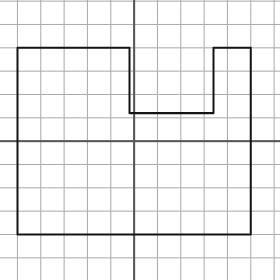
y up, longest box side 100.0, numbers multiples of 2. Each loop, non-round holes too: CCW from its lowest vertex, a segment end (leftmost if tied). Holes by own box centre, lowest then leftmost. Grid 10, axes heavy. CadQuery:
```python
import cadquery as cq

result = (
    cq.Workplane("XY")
    .moveTo(-50.0, -40.0)
    .lineTo(50.0, -40.0)
    .lineTo(50.0, 40.0)
    .lineTo(34.0, 40.0)
    .lineTo(34.0, 12.0)
    .lineTo(-2.0, 12.0)
    .lineTo(-2.0, 40.0)
    .lineTo(-50.0, 40.0)
    .close()
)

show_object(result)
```